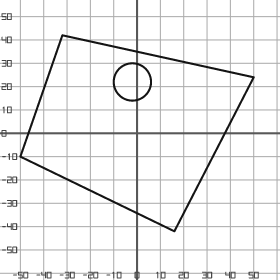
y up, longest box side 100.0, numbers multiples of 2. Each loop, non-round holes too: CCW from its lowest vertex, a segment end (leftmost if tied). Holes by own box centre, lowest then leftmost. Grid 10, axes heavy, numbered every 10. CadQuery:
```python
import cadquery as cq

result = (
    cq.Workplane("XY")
    .moveTo(16.0, -42.0)
    .lineTo(50.0, 24.0)
    .lineTo(-32.0, 42.0)
    .lineTo(-50.0, -10.0)
    .close()
    .moveTo(-2.0, 22.0)
    .circle(8.0)
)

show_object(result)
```